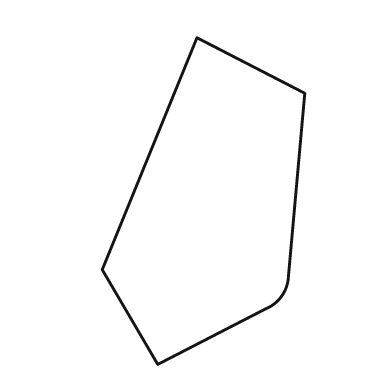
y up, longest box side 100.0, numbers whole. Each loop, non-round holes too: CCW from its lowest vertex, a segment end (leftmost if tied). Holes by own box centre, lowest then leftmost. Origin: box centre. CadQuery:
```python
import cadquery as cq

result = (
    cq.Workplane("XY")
    .moveTo(-14.0, -50.0)
    .lineTo(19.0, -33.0)
    .threePointArc((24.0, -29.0), (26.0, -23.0))
    .lineTo(31.0, 33.0)
    .lineTo(-2.0, 50.0)
    .lineTo(-31.0, -21.0)
    .close()
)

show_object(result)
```